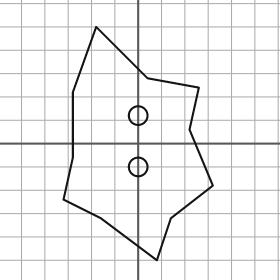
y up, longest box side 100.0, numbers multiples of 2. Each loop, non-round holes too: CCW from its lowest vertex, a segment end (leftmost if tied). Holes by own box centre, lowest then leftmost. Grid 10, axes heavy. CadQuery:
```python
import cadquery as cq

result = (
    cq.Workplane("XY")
    .moveTo(8.0, -50.0)
    .lineTo(14.0, -32.0)
    .lineTo(32.0, -18.0)
    .lineTo(22.0, 6.0)
    .lineTo(26.0, 24.0)
    .lineTo(4.0, 28.0)
    .lineTo(-18.0, 50.0)
    .lineTo(-28.0, 22.0)
    .lineTo(-28.0, -6.0)
    .lineTo(-32.0, -24.0)
    .lineTo(-16.0, -32.0)
    .close()
    .moveTo(0.0, -10.0)
    .circle(4.0)
    .moveTo(0.0, 12.0)
    .circle(4.0)
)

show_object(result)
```